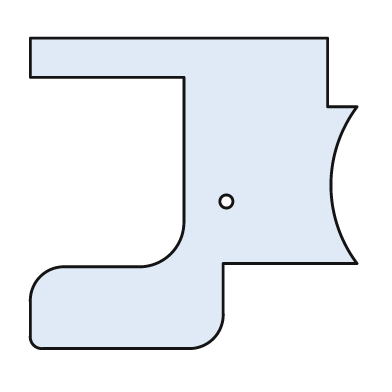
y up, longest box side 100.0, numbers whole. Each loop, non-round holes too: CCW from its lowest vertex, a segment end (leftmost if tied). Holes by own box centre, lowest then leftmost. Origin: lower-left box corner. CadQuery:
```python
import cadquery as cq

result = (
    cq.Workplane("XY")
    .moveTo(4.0, 0.0)
    .lineTo(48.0, 0.0)
    .threePointArc((56.0, 3.0), (59.0, 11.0))
    .lineTo(59.0, 26.0)
    .lineTo(100.0, 26.0)
    .threePointArc((92.0, 50.0), (100.0, 74.0))
    .lineTo(91.0, 74.0)
    .lineTo(91.0, 95.0)
    .lineTo(0.0, 95.0)
    .lineTo(0.0, 83.0)
    .lineTo(47.0, 83.0)
    .lineTo(47.0, 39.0)
    .threePointArc((43.0, 29.0), (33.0, 25.0))
    .lineTo(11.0, 25.0)
    .threePointArc((3.0, 22.0), (0.0, 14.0))
    .lineTo(0.0, 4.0)
    .threePointArc((1.0, 1.0), (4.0, 0.0))
    .close()
    .moveTo(60.0, 45.0)
    .circle(2.0)
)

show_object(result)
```